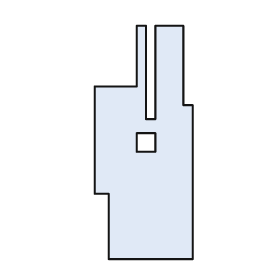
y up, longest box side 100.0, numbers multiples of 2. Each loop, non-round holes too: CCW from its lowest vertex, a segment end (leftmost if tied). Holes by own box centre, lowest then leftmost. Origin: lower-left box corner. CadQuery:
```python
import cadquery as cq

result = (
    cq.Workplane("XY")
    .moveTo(6.0, 0.0)
    .lineTo(42.0, 0.0)
    .lineTo(42.0, 66.0)
    .lineTo(38.0, 66.0)
    .lineTo(38.0, 100.0)
    .lineTo(26.0, 100.0)
    .lineTo(26.0, 60.0)
    .lineTo(22.0, 60.0)
    .lineTo(22.0, 100.0)
    .lineTo(18.0, 100.0)
    .lineTo(18.0, 74.0)
    .lineTo(0.0, 74.0)
    .lineTo(0.0, 28.0)
    .lineTo(6.0, 28.0)
    .close()
    .moveTo(18.0, 46.0)
    .lineTo(26.0, 46.0)
    .lineTo(26.0, 54.0)
    .lineTo(18.0, 54.0)
    .close()
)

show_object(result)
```